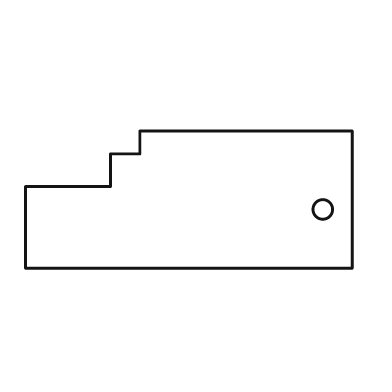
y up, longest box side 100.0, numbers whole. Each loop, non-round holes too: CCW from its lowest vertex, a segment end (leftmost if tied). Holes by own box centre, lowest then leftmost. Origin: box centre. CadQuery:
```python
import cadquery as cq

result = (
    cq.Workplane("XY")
    .moveTo(-50.0, -21.0)
    .lineTo(50.0, -21.0)
    .lineTo(50.0, 21.0)
    .lineTo(-15.0, 21.0)
    .lineTo(-15.0, 14.0)
    .lineTo(-24.0, 14.0)
    .lineTo(-24.0, 4.0)
    .lineTo(-50.0, 4.0)
    .close()
    .moveTo(41.0, -3.0)
    .circle(3.0)
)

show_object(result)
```